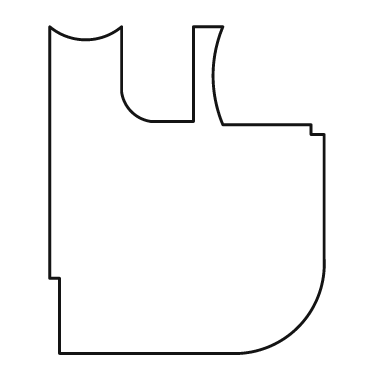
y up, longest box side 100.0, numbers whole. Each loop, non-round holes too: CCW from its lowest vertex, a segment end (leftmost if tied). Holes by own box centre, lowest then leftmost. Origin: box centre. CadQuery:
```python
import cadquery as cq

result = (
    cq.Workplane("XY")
    .moveTo(-39.0, -50.0)
    .lineTo(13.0, -50.0)
    .threePointArc((34.0, -42.0), (42.0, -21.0))
    .lineTo(42.0, 17.0)
    .lineTo(38.0, 17.0)
    .lineTo(38.0, 20.0)
    .lineTo(11.0, 20.0)
    .threePointArc((8.0, 35.0), (11.0, 50.0))
    .lineTo(2.0, 50.0)
    .lineTo(2.0, 21.0)
    .lineTo(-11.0, 21.0)
    .threePointArc((-17.0, 24.0), (-20.0, 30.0))
    .lineTo(-20.0, 50.0)
    .threePointArc((-31.0, 46.0), (-42.0, 50.0))
    .lineTo(-42.0, -27.0)
    .lineTo(-39.0, -27.0)
    .close()
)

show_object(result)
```